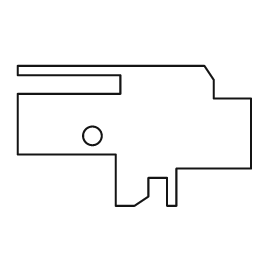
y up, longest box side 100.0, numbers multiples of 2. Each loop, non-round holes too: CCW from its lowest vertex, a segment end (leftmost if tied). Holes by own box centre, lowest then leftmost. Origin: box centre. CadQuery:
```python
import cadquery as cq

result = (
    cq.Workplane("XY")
    .moveTo(-8.0, -30.0)
    .lineTo(0.0, -30.0)
    .lineTo(6.0, -26.0)
    .lineTo(6.0, -18.0)
    .lineTo(14.0, -18.0)
    .lineTo(14.0, -30.0)
    .lineTo(18.0, -30.0)
    .lineTo(18.0, -14.0)
    .lineTo(50.0, -14.0)
    .lineTo(50.0, 16.0)
    .lineTo(34.0, 16.0)
    .lineTo(34.0, 24.0)
    .lineTo(30.0, 30.0)
    .lineTo(-50.0, 30.0)
    .lineTo(-50.0, 26.0)
    .lineTo(-6.0, 26.0)
    .lineTo(-6.0, 18.0)
    .lineTo(-50.0, 18.0)
    .lineTo(-50.0, -8.0)
    .lineTo(-8.0, -8.0)
    .close()
    .moveTo(-18.0, 0.0)
    .circle(4.0)
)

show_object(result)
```